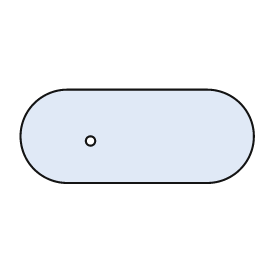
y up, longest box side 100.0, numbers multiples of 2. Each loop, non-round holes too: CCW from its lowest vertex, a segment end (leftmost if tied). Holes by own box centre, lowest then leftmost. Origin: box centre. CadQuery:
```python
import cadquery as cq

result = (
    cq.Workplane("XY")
    .moveTo(-30.0, -20.0)
    .lineTo(30.0, -20.0)
    .threePointArc((50.0, 0.0), (30.0, 20.0))
    .lineTo(-30.0, 20.0)
    .threePointArc((-50.0, 0.0), (-30.0, -20.0))
    .close()
    .moveTo(-20.0, -2.0)
    .circle(2.0)
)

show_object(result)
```